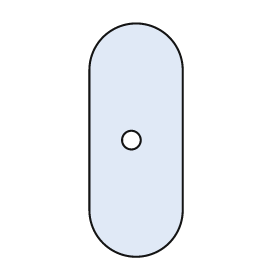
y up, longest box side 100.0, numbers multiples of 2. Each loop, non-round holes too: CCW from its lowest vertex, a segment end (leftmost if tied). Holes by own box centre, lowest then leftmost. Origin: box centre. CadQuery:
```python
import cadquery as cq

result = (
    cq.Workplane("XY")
    .moveTo(-20.0, -30.0)
    .threePointArc((0.0, -50.0), (20.0, -30.0))
    .lineTo(20.0, 30.0)
    .threePointArc((0.0, 50.0), (-20.0, 30.0))
    .close()
    .moveTo(-2.0, 0.0)
    .circle(4.0)
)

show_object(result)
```